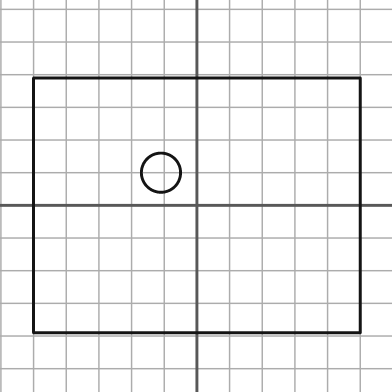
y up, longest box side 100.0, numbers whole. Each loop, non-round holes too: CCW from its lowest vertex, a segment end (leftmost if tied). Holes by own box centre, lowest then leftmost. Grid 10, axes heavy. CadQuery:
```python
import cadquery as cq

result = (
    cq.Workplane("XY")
    .moveTo(-50.0, -39.0)
    .lineTo(50.0, -39.0)
    .lineTo(50.0, 39.0)
    .lineTo(-50.0, 39.0)
    .close()
    .moveTo(-11.0, 10.0)
    .circle(6.0)
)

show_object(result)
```